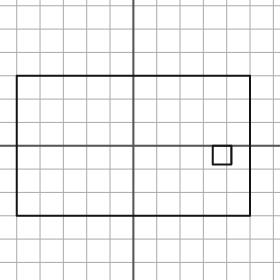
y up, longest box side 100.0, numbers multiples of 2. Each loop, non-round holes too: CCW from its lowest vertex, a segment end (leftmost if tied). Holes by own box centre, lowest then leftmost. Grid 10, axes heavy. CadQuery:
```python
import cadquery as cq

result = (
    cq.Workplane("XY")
    .moveTo(-50.0, -30.0)
    .lineTo(50.0, -30.0)
    .lineTo(50.0, 30.0)
    .lineTo(-50.0, 30.0)
    .close()
    .moveTo(34.0, -8.0)
    .lineTo(42.0, -8.0)
    .lineTo(42.0, 0.0)
    .lineTo(34.0, 0.0)
    .close()
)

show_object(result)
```